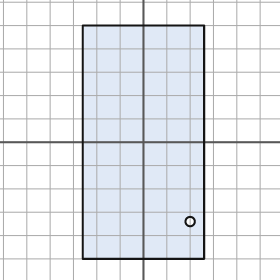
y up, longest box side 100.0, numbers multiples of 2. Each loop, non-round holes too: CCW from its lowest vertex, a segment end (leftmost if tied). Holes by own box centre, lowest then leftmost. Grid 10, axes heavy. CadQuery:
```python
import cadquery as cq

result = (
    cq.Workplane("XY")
    .moveTo(-26.0, -50.0)
    .lineTo(26.0, -50.0)
    .lineTo(26.0, 50.0)
    .lineTo(-26.0, 50.0)
    .close()
    .moveTo(20.0, -34.0)
    .circle(2.0)
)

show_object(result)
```